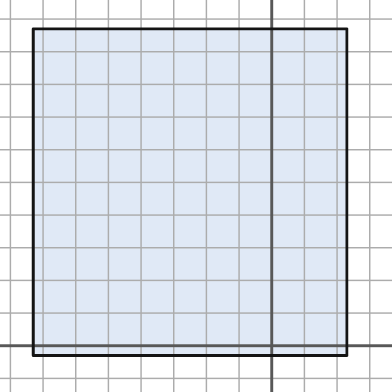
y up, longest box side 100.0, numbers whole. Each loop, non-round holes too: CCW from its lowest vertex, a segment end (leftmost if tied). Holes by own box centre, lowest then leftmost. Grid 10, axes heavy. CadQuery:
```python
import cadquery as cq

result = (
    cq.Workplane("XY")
    .moveTo(-73.0, -3.0)
    .lineTo(23.0, -3.0)
    .lineTo(23.0, 97.0)
    .lineTo(-73.0, 97.0)
    .close()
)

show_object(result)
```